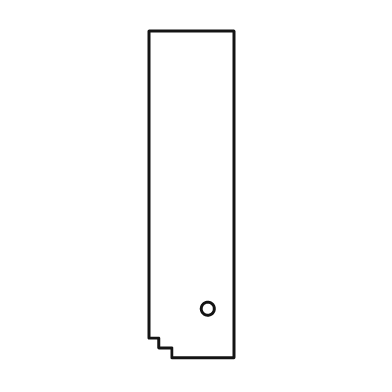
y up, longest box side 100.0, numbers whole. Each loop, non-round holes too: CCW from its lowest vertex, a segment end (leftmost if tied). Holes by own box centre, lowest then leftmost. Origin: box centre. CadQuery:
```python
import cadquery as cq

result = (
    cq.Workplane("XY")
    .moveTo(-6.0, -50.0)
    .lineTo(13.0, -50.0)
    .lineTo(13.0, 50.0)
    .lineTo(-13.0, 50.0)
    .lineTo(-13.0, -44.0)
    .lineTo(-10.0, -44.0)
    .lineTo(-10.0, -47.0)
    .lineTo(-6.0, -47.0)
    .close()
    .moveTo(5.0, -35.0)
    .circle(2.0)
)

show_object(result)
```